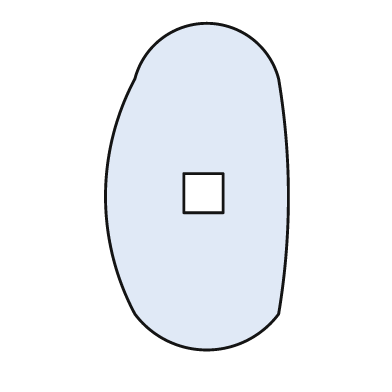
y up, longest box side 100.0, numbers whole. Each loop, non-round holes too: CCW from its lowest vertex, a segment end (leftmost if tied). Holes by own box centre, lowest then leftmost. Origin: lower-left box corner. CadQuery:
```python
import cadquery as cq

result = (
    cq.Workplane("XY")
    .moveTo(9.0, 11.0)
    .threePointArc((31.0, 0.0), (53.0, 11.0))
    .threePointArc((56.0, 47.0), (53.0, 83.0))
    .threePointArc((31.0, 100.0), (9.0, 83.0))
    .threePointArc((0.0, 47.0), (9.0, 11.0))
    .close()
    .moveTo(24.0, 42.0)
    .lineTo(36.0, 42.0)
    .lineTo(36.0, 54.0)
    .lineTo(24.0, 54.0)
    .close()
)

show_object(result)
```